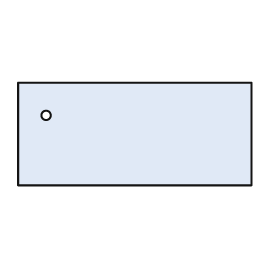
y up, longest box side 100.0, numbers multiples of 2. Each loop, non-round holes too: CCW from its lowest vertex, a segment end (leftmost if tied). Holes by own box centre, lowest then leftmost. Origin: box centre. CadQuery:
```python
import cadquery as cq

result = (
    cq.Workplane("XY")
    .moveTo(-50.0, -22.0)
    .lineTo(50.0, -22.0)
    .lineTo(50.0, 22.0)
    .lineTo(-50.0, 22.0)
    .close()
    .moveTo(-38.0, 8.0)
    .circle(2.0)
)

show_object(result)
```